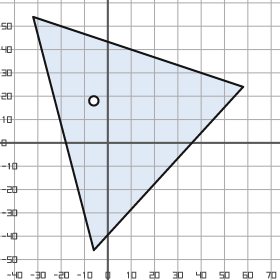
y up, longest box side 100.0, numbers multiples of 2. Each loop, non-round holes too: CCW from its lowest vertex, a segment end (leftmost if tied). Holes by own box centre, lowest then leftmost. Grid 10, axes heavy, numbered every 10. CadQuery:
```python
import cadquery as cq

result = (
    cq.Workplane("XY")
    .moveTo(-6.0, -46.0)
    .lineTo(58.0, 24.0)
    .lineTo(-32.0, 54.0)
    .close()
    .moveTo(-6.0, 18.0)
    .circle(2.0)
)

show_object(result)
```